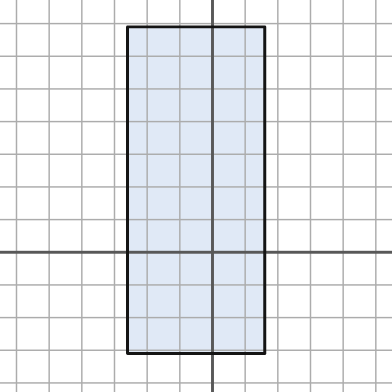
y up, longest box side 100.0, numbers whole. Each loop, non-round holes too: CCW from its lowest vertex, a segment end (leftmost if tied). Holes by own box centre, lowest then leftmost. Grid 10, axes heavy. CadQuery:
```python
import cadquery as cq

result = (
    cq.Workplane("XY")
    .moveTo(-26.0, -31.0)
    .lineTo(16.0, -31.0)
    .lineTo(16.0, 69.0)
    .lineTo(-26.0, 69.0)
    .close()
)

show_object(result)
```